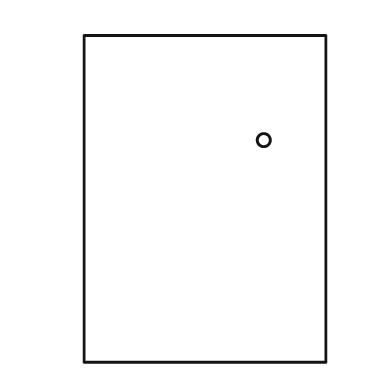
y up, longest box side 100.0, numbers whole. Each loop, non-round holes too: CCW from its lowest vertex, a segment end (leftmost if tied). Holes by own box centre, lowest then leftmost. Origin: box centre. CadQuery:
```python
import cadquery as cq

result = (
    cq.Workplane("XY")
    .moveTo(-37.0, -50.0)
    .lineTo(37.0, -50.0)
    .lineTo(37.0, 50.0)
    .lineTo(-37.0, 50.0)
    .close()
    .moveTo(18.0, 18.0)
    .circle(2.0)
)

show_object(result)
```